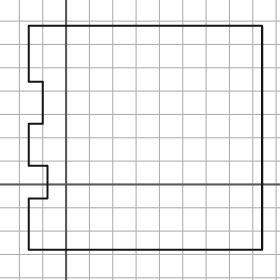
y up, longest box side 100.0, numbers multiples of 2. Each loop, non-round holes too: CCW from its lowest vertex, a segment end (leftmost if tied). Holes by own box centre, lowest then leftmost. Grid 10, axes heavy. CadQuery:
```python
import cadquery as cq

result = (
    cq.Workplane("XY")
    .moveTo(-16.0, -28.0)
    .lineTo(84.0, -28.0)
    .lineTo(84.0, 68.0)
    .lineTo(-16.0, 68.0)
    .lineTo(-16.0, 44.0)
    .lineTo(-10.0, 44.0)
    .lineTo(-10.0, 26.0)
    .lineTo(-16.0, 26.0)
    .lineTo(-16.0, 8.0)
    .lineTo(-8.0, 8.0)
    .lineTo(-8.0, -6.0)
    .lineTo(-16.0, -6.0)
    .close()
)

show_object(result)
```